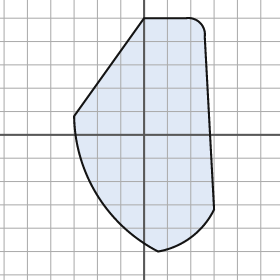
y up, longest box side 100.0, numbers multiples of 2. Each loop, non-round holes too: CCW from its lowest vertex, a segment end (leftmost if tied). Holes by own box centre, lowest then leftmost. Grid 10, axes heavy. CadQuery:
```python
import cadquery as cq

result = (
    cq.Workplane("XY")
    .moveTo(6.0, -50.0)
    .threePointArc((20.0, -44.0), (30.0, -32.0))
    .lineTo(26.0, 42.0)
    .threePointArc((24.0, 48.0), (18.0, 50.0))
    .lineTo(0.0, 50.0)
    .lineTo(-30.0, 8.0)
    .threePointArc((-20.0, -26.0), (6.0, -50.0))
    .close()
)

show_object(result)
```